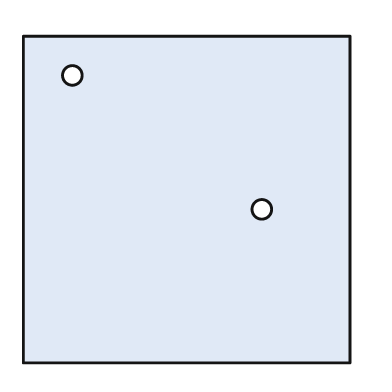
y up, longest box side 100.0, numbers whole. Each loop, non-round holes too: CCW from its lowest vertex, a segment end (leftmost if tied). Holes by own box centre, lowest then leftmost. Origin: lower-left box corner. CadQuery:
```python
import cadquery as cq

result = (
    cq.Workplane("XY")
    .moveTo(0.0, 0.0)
    .lineTo(100.0, 0.0)
    .lineTo(100.0, 100.0)
    .lineTo(0.0, 100.0)
    .close()
    .moveTo(73.0, 47.0)
    .circle(3.0)
    .moveTo(15.0, 88.0)
    .circle(3.0)
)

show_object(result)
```